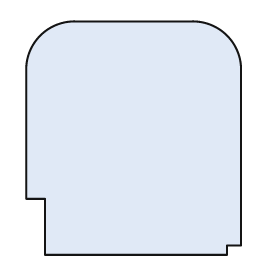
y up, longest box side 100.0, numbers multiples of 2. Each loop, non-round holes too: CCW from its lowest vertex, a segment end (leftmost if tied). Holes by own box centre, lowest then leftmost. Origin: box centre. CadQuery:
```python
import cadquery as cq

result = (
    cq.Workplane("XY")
    .moveTo(-38.0, -50.0)
    .lineTo(40.0, -50.0)
    .lineTo(40.0, -46.0)
    .lineTo(46.0, -46.0)
    .lineTo(46.0, 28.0)
    .threePointArc((40.0, 44.0), (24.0, 50.0))
    .lineTo(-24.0, 50.0)
    .threePointArc((-40.0, 44.0), (-46.0, 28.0))
    .lineTo(-46.0, -26.0)
    .lineTo(-38.0, -26.0)
    .close()
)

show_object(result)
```